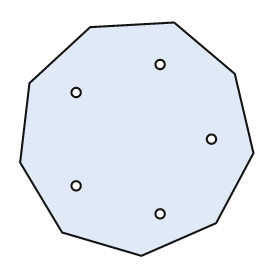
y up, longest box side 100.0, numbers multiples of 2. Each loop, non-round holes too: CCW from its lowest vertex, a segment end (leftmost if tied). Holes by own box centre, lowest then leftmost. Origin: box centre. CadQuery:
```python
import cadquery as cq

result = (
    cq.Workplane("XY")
    .moveTo(2.0, -50.0)
    .lineTo(34.0, -36.0)
    .lineTo(50.0, -6.0)
    .lineTo(42.0, 28.0)
    .lineTo(16.0, 50.0)
    .lineTo(-20.0, 48.0)
    .lineTo(-46.0, 24.0)
    .lineTo(-50.0, -10.0)
    .lineTo(-32.0, -40.0)
    .close()
    .moveTo(10.0, -32.0)
    .circle(2.0)
    .moveTo(-26.0, -20.0)
    .circle(2.0)
    .moveTo(32.0, 0.0)
    .circle(2.0)
    .moveTo(-26.0, 20.0)
    .circle(2.0)
    .moveTo(10.0, 32.0)
    .circle(2.0)
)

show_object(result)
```